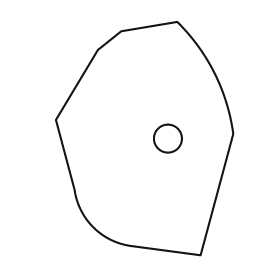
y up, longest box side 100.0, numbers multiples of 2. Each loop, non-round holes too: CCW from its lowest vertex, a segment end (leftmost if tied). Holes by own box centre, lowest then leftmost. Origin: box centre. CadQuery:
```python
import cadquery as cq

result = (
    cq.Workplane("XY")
    .moveTo(24.0, -50.0)
    .lineTo(38.0, 2.0)
    .threePointArc((30.0, 28.0), (14.0, 50.0))
    .lineTo(-10.0, 46.0)
    .lineTo(-20.0, 38.0)
    .lineTo(-38.0, 8.0)
    .lineTo(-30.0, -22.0)
    .threePointArc((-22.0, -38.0), (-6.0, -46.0))
    .close()
    .moveTo(10.0, 0.0)
    .circle(6.0)
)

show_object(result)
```